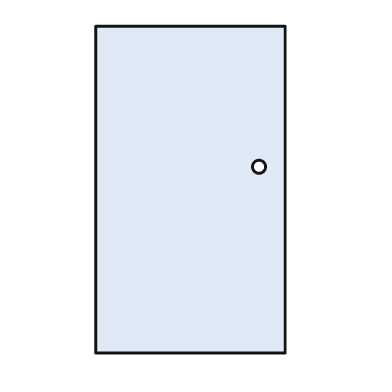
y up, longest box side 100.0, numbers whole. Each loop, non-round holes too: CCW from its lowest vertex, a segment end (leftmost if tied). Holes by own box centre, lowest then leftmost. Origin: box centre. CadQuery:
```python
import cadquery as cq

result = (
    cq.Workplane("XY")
    .moveTo(-29.0, -50.0)
    .lineTo(29.0, -50.0)
    .lineTo(29.0, 50.0)
    .lineTo(-29.0, 50.0)
    .close()
    .moveTo(21.0, 7.0)
    .circle(2.0)
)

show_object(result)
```